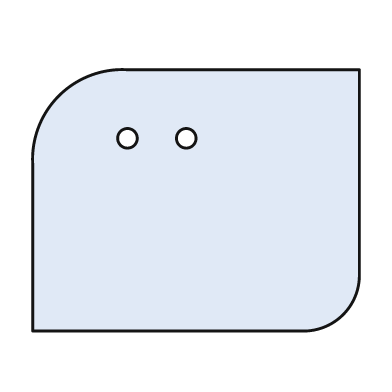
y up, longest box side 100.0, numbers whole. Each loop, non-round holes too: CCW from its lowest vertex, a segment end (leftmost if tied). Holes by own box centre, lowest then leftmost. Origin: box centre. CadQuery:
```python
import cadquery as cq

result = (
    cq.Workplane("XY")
    .moveTo(-50.0, -40.0)
    .lineTo(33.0, -40.0)
    .threePointArc((45.0, -35.0), (50.0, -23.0))
    .lineTo(50.0, 40.0)
    .lineTo(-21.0, 40.0)
    .threePointArc((-42.0, 32.0), (-50.0, 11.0))
    .close()
    .moveTo(-21.0, 19.0)
    .circle(3.0)
    .moveTo(-3.0, 19.0)
    .circle(3.0)
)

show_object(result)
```